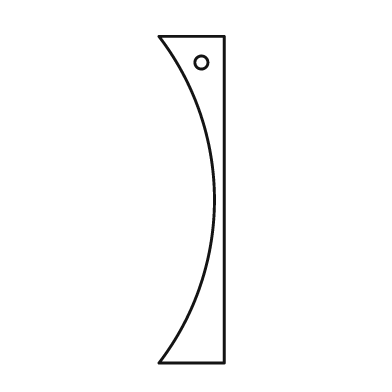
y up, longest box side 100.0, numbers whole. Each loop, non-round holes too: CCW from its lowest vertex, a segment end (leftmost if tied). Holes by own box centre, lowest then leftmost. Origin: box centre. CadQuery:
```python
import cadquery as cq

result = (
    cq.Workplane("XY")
    .moveTo(-10.0, -50.0)
    .lineTo(10.0, -50.0)
    .lineTo(10.0, 50.0)
    .lineTo(-10.0, 50.0)
    .threePointArc((7.0, 0.0), (-10.0, -50.0))
    .close()
    .moveTo(3.0, 42.0)
    .circle(2.0)
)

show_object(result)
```